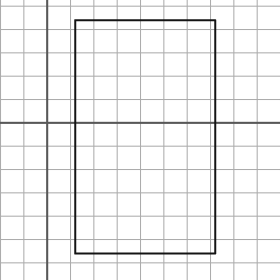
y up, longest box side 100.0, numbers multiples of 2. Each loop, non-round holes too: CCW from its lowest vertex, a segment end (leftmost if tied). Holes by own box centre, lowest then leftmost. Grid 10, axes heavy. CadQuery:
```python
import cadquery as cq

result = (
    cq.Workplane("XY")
    .moveTo(12.0, -56.0)
    .lineTo(72.0, -56.0)
    .lineTo(72.0, 44.0)
    .lineTo(12.0, 44.0)
    .close()
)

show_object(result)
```